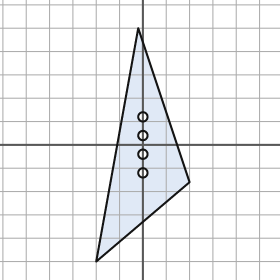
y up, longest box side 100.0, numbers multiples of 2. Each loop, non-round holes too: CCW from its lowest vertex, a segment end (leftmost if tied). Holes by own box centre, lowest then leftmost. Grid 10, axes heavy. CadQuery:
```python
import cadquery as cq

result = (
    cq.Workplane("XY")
    .moveTo(-20.0, -50.0)
    .lineTo(20.0, -16.0)
    .lineTo(-2.0, 50.0)
    .close()
    .moveTo(0.0, -12.0)
    .circle(2.0)
    .moveTo(0.0, -4.0)
    .circle(2.0)
    .moveTo(0.0, 4.0)
    .circle(2.0)
    .moveTo(0.0, 12.0)
    .circle(2.0)
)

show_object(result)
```